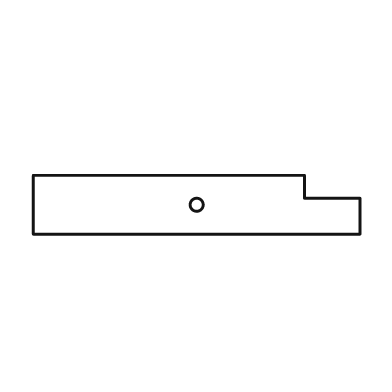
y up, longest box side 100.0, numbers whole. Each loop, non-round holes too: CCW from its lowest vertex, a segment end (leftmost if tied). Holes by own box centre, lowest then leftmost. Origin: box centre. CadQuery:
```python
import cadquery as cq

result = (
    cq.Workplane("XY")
    .moveTo(-50.0, -9.0)
    .lineTo(50.0, -9.0)
    .lineTo(50.0, 2.0)
    .lineTo(33.0, 2.0)
    .lineTo(33.0, 9.0)
    .lineTo(-50.0, 9.0)
    .close()
    .moveTo(0.0, 0.0)
    .circle(2.0)
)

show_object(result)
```